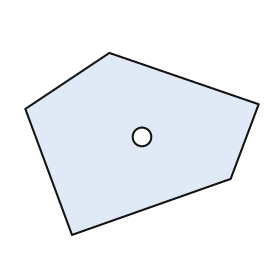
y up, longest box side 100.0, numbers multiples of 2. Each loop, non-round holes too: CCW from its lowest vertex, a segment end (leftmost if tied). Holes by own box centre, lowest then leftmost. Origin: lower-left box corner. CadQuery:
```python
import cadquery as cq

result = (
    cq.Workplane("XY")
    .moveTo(20.0, 0.0)
    .lineTo(88.0, 24.0)
    .lineTo(100.0, 56.0)
    .lineTo(36.0, 78.0)
    .lineTo(0.0, 54.0)
    .close()
    .moveTo(50.0, 42.0)
    .circle(4.0)
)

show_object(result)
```